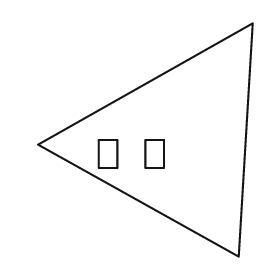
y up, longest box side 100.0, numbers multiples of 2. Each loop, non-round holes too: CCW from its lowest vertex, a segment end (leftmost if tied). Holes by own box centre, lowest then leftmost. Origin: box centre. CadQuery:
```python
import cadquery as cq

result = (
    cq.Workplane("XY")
    .moveTo(40.0, -50.0)
    .lineTo(46.0, 50.0)
    .lineTo(-46.0, -2.0)
    .close()
    .moveTo(-20.0, -12.0)
    .lineTo(-12.0, -12.0)
    .lineTo(-12.0, 0.0)
    .lineTo(-20.0, 0.0)
    .close()
    .moveTo(0.0, -12.0)
    .lineTo(8.0, -12.0)
    .lineTo(8.0, 0.0)
    .lineTo(0.0, 0.0)
    .close()
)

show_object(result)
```